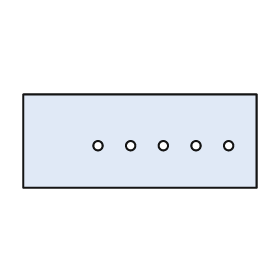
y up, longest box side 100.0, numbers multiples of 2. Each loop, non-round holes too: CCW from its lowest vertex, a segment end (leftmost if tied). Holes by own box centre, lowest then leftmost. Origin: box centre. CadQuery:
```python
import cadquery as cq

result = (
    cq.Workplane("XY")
    .moveTo(-50.0, -20.0)
    .lineTo(50.0, -20.0)
    .lineTo(50.0, 20.0)
    .lineTo(-50.0, 20.0)
    .close()
    .moveTo(-18.0, -2.0)
    .circle(2.0)
    .moveTo(-4.0, -2.0)
    .circle(2.0)
    .moveTo(10.0, -2.0)
    .circle(2.0)
    .moveTo(24.0, -2.0)
    .circle(2.0)
    .moveTo(38.0, -2.0)
    .circle(2.0)
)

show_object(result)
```